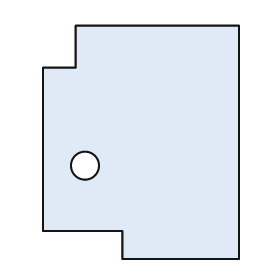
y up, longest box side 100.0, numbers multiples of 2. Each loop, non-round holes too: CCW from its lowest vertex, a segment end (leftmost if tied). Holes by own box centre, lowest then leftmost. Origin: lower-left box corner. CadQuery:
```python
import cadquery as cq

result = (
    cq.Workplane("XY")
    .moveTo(34.0, 0.0)
    .lineTo(84.0, 0.0)
    .lineTo(84.0, 100.0)
    .lineTo(14.0, 100.0)
    .lineTo(14.0, 82.0)
    .lineTo(0.0, 82.0)
    .lineTo(0.0, 12.0)
    .lineTo(34.0, 12.0)
    .close()
    .moveTo(18.0, 40.0)
    .circle(6.0)
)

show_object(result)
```